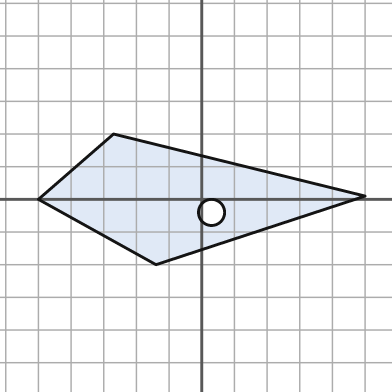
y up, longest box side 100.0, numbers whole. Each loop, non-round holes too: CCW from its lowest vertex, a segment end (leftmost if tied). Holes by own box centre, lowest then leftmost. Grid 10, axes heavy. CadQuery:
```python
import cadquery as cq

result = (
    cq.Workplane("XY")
    .moveTo(-14.0, -20.0)
    .lineTo(50.0, 1.0)
    .lineTo(-27.0, 20.0)
    .lineTo(-50.0, 0.0)
    .close()
    .moveTo(3.0, -4.0)
    .circle(4.0)
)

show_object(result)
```